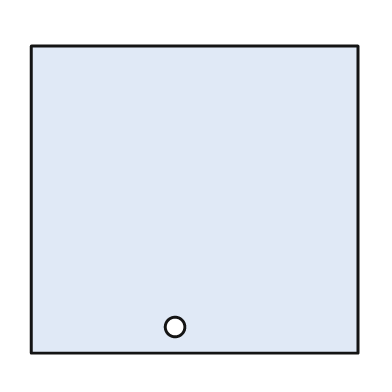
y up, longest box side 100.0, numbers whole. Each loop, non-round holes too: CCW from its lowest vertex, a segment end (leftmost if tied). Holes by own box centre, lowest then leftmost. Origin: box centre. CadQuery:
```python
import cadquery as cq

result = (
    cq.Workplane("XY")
    .moveTo(-50.0, -47.0)
    .lineTo(50.0, -47.0)
    .lineTo(50.0, 47.0)
    .lineTo(-50.0, 47.0)
    .close()
    .moveTo(-6.0, -39.0)
    .circle(3.0)
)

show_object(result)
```